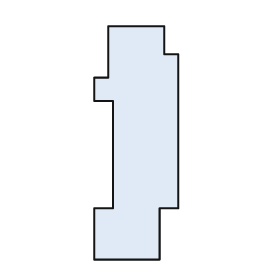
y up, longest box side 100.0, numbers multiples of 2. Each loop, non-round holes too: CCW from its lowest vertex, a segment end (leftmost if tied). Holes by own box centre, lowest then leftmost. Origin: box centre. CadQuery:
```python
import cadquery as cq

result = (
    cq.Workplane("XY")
    .moveTo(-18.0, -50.0)
    .lineTo(10.0, -50.0)
    .lineTo(10.0, -28.0)
    .lineTo(18.0, -28.0)
    .lineTo(18.0, 38.0)
    .lineTo(12.0, 38.0)
    .lineTo(12.0, 50.0)
    .lineTo(-12.0, 50.0)
    .lineTo(-12.0, 28.0)
    .lineTo(-18.0, 28.0)
    .lineTo(-18.0, 18.0)
    .lineTo(-10.0, 18.0)
    .lineTo(-10.0, -28.0)
    .lineTo(-18.0, -28.0)
    .close()
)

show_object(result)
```